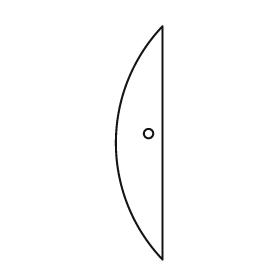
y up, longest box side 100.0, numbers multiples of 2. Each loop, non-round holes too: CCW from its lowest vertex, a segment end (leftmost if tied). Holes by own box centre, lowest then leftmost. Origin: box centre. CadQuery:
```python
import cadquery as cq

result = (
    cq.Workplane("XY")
    .moveTo(10.0, -50.0)
    .lineTo(10.0, 50.0)
    .threePointArc((-10.0, 0.0), (10.0, -50.0))
    .close()
    .moveTo(4.0, 4.0)
    .circle(2.0)
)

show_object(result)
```